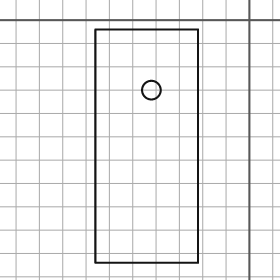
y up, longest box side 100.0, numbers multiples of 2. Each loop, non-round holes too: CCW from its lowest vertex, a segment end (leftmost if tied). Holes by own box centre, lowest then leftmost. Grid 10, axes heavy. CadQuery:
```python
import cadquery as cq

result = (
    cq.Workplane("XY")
    .moveTo(-66.0, -104.0)
    .lineTo(-22.0, -104.0)
    .lineTo(-22.0, -4.0)
    .lineTo(-66.0, -4.0)
    .close()
    .moveTo(-42.0, -30.0)
    .circle(4.0)
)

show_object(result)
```